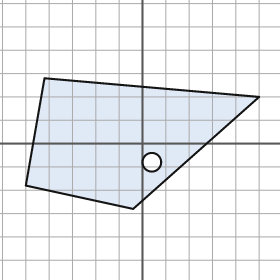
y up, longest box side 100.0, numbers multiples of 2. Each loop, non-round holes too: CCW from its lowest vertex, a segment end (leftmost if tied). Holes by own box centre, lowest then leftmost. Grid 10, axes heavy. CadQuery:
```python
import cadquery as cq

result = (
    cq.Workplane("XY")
    .moveTo(-4.0, -28.0)
    .lineTo(50.0, 20.0)
    .lineTo(-42.0, 28.0)
    .lineTo(-50.0, -18.0)
    .close()
    .moveTo(4.0, -8.0)
    .circle(4.0)
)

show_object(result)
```